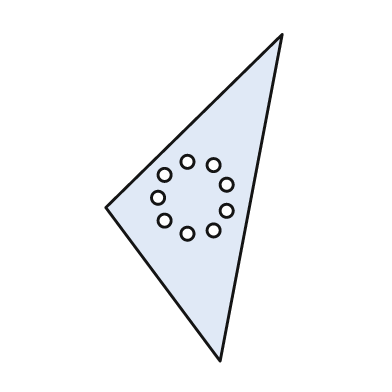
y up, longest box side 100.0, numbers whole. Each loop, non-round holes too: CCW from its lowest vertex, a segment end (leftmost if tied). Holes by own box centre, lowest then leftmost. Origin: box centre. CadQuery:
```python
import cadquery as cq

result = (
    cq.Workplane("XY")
    .moveTo(8.0, -50.0)
    .lineTo(27.0, 50.0)
    .lineTo(-27.0, -3.0)
    .close()
    .moveTo(-2.0, -11.0)
    .circle(2.0)
    .moveTo(6.0, -10.0)
    .circle(2.0)
    .moveTo(-9.0, -7.0)
    .circle(2.0)
    .moveTo(10.0, -4.0)
    .circle(2.0)
    .moveTo(-11.0, 0.0)
    .circle(2.0)
    .moveTo(10.0, 4.0)
    .circle(2.0)
    .moveTo(-9.0, 7.0)
    .circle(2.0)
    .moveTo(6.0, 10.0)
    .circle(2.0)
    .moveTo(-2.0, 11.0)
    .circle(2.0)
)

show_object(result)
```